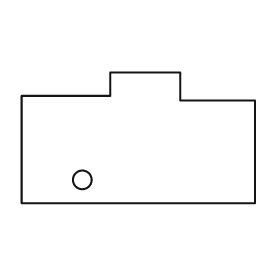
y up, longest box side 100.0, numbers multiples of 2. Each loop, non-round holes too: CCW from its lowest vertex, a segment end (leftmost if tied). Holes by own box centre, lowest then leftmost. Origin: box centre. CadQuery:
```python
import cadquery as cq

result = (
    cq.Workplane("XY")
    .moveTo(-50.0, -28.0)
    .lineTo(50.0, -28.0)
    .lineTo(50.0, 16.0)
    .lineTo(18.0, 16.0)
    .lineTo(18.0, 28.0)
    .lineTo(-12.0, 28.0)
    .lineTo(-12.0, 18.0)
    .lineTo(-50.0, 18.0)
    .close()
    .moveTo(-24.0, -18.0)
    .circle(4.0)
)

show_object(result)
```